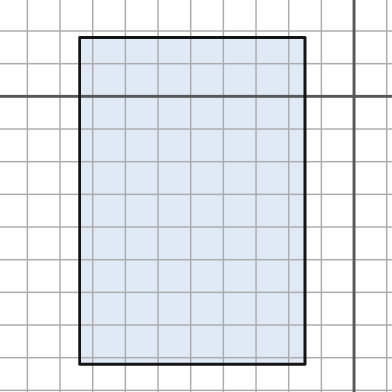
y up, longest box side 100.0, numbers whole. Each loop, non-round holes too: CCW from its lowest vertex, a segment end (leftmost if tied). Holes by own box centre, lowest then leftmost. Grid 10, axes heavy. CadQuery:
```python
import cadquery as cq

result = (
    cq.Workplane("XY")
    .moveTo(-84.0, -82.0)
    .lineTo(-15.0, -82.0)
    .lineTo(-15.0, 18.0)
    .lineTo(-84.0, 18.0)
    .close()
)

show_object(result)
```